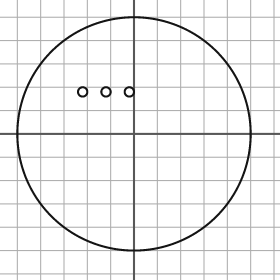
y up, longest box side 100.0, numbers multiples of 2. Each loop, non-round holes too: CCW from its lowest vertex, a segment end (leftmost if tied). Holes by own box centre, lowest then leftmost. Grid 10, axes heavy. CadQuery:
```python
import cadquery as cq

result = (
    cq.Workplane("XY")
    .moveTo(0.0, 0.0)
    .circle(50.0)
    .moveTo(-22.0, 18.0)
    .circle(2.0)
    .moveTo(-12.0, 18.0)
    .circle(2.0)
    .moveTo(-2.0, 18.0)
    .circle(2.0)
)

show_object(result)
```